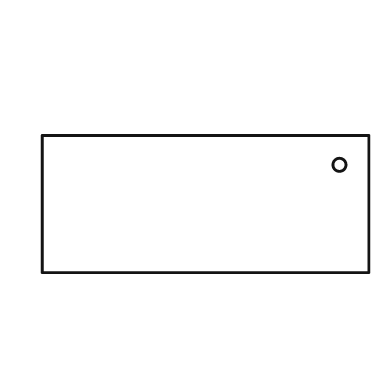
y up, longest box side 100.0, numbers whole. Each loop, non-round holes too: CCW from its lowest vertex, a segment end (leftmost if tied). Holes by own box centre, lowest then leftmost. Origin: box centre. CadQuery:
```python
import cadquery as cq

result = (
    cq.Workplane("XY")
    .moveTo(-50.0, -21.0)
    .lineTo(50.0, -21.0)
    .lineTo(50.0, 21.0)
    .lineTo(-50.0, 21.0)
    .close()
    .moveTo(41.0, 12.0)
    .circle(2.0)
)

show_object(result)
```